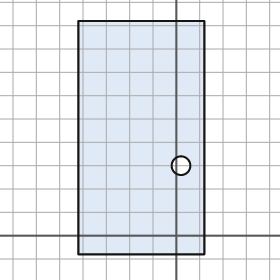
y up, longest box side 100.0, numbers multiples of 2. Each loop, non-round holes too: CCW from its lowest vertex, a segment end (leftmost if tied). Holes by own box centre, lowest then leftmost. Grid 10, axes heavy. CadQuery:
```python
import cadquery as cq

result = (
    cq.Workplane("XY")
    .moveTo(-42.0, -8.0)
    .lineTo(12.0, -8.0)
    .lineTo(12.0, 92.0)
    .lineTo(-42.0, 92.0)
    .close()
    .moveTo(2.0, 30.0)
    .circle(4.0)
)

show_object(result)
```